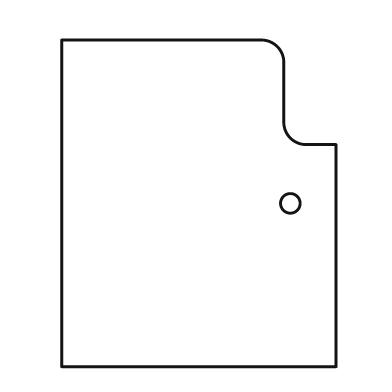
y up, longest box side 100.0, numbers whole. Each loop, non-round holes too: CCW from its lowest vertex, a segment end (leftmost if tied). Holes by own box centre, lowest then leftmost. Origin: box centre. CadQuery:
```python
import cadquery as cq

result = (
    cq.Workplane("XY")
    .moveTo(-42.0, -50.0)
    .lineTo(42.0, -50.0)
    .lineTo(42.0, 18.0)
    .lineTo(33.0, 18.0)
    .threePointArc((28.0, 20.0), (26.0, 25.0))
    .lineTo(26.0, 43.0)
    .threePointArc((24.0, 48.0), (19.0, 50.0))
    .lineTo(-42.0, 50.0)
    .close()
    .moveTo(28.0, 0.0)
    .circle(3.0)
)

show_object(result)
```